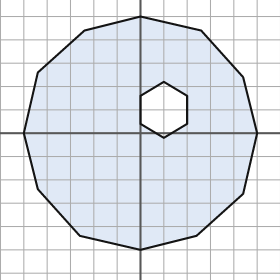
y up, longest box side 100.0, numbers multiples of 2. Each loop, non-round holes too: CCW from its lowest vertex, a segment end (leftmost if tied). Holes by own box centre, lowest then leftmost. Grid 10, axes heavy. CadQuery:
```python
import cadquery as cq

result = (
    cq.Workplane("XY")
    .moveTo(0.0, -50.0)
    .lineTo(24.0, -44.0)
    .lineTo(44.0, -26.0)
    .lineTo(50.0, 0.0)
    .lineTo(44.0, 24.0)
    .lineTo(26.0, 44.0)
    .lineTo(0.0, 50.0)
    .lineTo(-24.0, 44.0)
    .lineTo(-44.0, 26.0)
    .lineTo(-50.0, 0.0)
    .lineTo(-44.0, -24.0)
    .lineTo(-26.0, -44.0)
    .close()
    .moveTo(10.0, -2.0)
    .lineTo(20.0, 4.0)
    .lineTo(20.0, 16.0)
    .lineTo(10.0, 22.0)
    .lineTo(0.0, 16.0)
    .lineTo(0.0, 4.0)
    .close()
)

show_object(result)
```